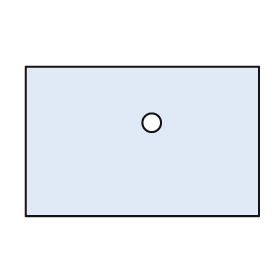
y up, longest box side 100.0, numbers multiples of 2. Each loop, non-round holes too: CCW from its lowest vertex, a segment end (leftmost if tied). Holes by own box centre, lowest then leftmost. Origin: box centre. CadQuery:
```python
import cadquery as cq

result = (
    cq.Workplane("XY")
    .moveTo(-50.0, -32.0)
    .lineTo(50.0, -32.0)
    .lineTo(50.0, 32.0)
    .lineTo(-50.0, 32.0)
    .close()
    .moveTo(4.0, 8.0)
    .circle(4.0)
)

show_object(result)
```